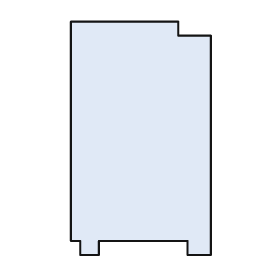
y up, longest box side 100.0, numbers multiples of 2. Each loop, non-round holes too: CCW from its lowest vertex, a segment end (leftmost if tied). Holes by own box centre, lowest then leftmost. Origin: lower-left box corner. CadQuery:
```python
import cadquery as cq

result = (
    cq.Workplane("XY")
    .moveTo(4.0, 0.0)
    .lineTo(12.0, 0.0)
    .lineTo(12.0, 6.0)
    .lineTo(50.0, 6.0)
    .lineTo(50.0, 0.0)
    .lineTo(60.0, 0.0)
    .lineTo(60.0, 94.0)
    .lineTo(46.0, 94.0)
    .lineTo(46.0, 100.0)
    .lineTo(0.0, 100.0)
    .lineTo(0.0, 6.0)
    .lineTo(4.0, 6.0)
    .close()
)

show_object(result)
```